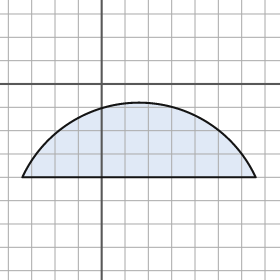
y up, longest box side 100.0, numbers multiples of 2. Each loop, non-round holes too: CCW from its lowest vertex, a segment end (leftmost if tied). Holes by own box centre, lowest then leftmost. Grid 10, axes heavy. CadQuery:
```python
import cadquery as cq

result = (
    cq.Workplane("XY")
    .moveTo(-34.0, -40.0)
    .lineTo(66.0, -40.0)
    .threePointArc((16.0, -8.0), (-34.0, -40.0))
    .close()
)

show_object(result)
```